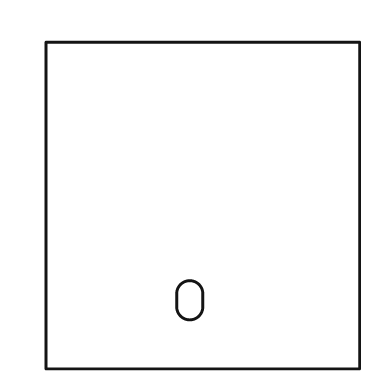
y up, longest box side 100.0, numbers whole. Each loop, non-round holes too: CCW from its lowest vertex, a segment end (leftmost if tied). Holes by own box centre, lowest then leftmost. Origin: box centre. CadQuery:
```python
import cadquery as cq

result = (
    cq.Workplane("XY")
    .moveTo(-48.0, -50.0)
    .lineTo(48.0, -50.0)
    .lineTo(48.0, 50.0)
    .lineTo(-48.0, 50.0)
    .close()
    .moveTo(-8.0, -31.0)
    .threePointArc((-4.0, -35.0), (0.0, -31.0))
    .lineTo(0.0, -27.0)
    .threePointArc((-4.0, -23.0), (-8.0, -27.0))
    .close()
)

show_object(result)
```